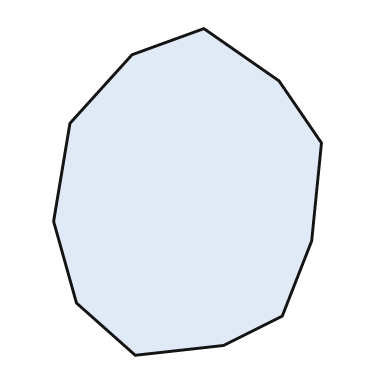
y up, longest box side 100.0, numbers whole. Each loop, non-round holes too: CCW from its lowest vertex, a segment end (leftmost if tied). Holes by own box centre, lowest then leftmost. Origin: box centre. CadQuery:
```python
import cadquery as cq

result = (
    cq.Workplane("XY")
    .moveTo(-16.0, -50.0)
    .lineTo(11.0, -47.0)
    .lineTo(29.0, -38.0)
    .lineTo(38.0, -15.0)
    .lineTo(41.0, 15.0)
    .lineTo(28.0, 34.0)
    .lineTo(5.0, 50.0)
    .lineTo(-17.0, 42.0)
    .lineTo(-36.0, 21.0)
    .lineTo(-41.0, -9.0)
    .lineTo(-34.0, -34.0)
    .close()
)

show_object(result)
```